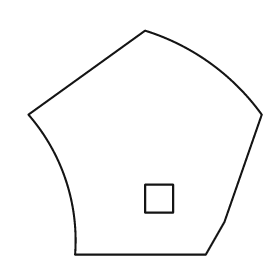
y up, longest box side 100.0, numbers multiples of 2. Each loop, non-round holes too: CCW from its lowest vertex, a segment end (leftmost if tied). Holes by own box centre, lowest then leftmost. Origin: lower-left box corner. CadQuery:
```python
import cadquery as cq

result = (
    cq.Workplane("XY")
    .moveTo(20.0, 0.0)
    .lineTo(76.0, 0.0)
    .lineTo(84.0, 14.0)
    .lineTo(100.0, 60.0)
    .threePointArc((78.0, 82.0), (50.0, 96.0))
    .lineTo(0.0, 60.0)
    .threePointArc((16.0, 32.0), (20.0, 0.0))
    .close()
    .moveTo(50.0, 18.0)
    .lineTo(62.0, 18.0)
    .lineTo(62.0, 30.0)
    .lineTo(50.0, 30.0)
    .close()
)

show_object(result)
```